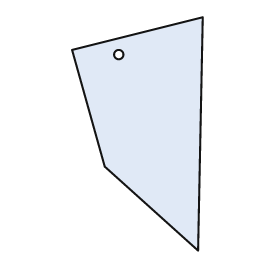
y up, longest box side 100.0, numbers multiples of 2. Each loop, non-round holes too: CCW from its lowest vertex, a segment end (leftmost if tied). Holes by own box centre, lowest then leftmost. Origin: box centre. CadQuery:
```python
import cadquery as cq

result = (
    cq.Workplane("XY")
    .moveTo(26.0, -50.0)
    .lineTo(28.0, 50.0)
    .lineTo(-28.0, 36.0)
    .lineTo(-14.0, -14.0)
    .close()
    .moveTo(-8.0, 34.0)
    .circle(2.0)
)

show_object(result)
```